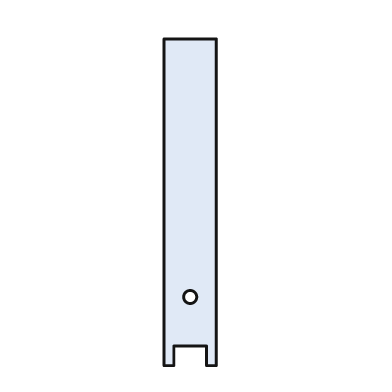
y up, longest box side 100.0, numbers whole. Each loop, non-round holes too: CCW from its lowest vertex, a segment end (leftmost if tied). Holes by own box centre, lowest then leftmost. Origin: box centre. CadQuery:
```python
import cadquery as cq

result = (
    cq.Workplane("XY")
    .moveTo(-8.0, -50.0)
    .lineTo(-5.0, -50.0)
    .lineTo(-5.0, -44.0)
    .lineTo(5.0, -44.0)
    .lineTo(5.0, -50.0)
    .lineTo(8.0, -50.0)
    .lineTo(8.0, 50.0)
    .lineTo(-8.0, 50.0)
    .close()
    .moveTo(0.0, -29.0)
    .circle(2.0)
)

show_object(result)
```